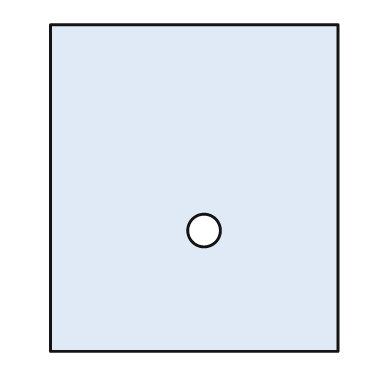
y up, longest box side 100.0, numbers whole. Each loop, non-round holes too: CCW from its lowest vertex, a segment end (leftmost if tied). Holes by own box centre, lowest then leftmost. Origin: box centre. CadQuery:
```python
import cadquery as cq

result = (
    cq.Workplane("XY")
    .moveTo(-44.0, -50.0)
    .lineTo(44.0, -50.0)
    .lineTo(44.0, 50.0)
    .lineTo(-44.0, 50.0)
    .close()
    .moveTo(3.0, -13.0)
    .circle(5.0)
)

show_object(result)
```